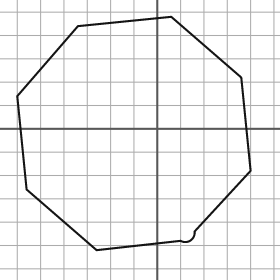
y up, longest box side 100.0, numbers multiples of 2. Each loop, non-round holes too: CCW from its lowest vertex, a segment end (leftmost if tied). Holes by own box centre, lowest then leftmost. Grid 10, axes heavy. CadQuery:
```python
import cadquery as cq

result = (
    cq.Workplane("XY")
    .moveTo(-26.0, -52.0)
    .lineTo(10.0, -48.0)
    .threePointArc((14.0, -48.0), (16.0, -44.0))
    .lineTo(40.0, -18.0)
    .lineTo(36.0, 22.0)
    .lineTo(6.0, 48.0)
    .lineTo(-34.0, 44.0)
    .lineTo(-60.0, 14.0)
    .lineTo(-56.0, -26.0)
    .close()
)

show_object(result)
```